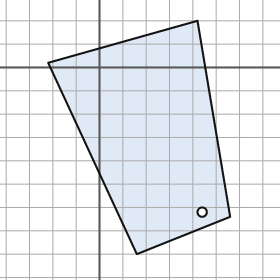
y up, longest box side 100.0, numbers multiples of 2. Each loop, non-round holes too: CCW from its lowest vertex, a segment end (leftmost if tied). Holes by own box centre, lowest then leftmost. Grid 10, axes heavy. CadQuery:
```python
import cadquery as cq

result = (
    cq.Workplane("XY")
    .moveTo(16.0, -80.0)
    .lineTo(56.0, -64.0)
    .lineTo(42.0, 20.0)
    .lineTo(-22.0, 2.0)
    .close()
    .moveTo(44.0, -62.0)
    .circle(2.0)
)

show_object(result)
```